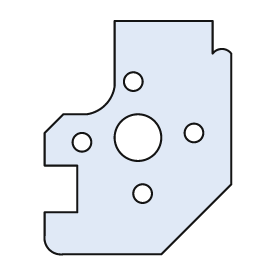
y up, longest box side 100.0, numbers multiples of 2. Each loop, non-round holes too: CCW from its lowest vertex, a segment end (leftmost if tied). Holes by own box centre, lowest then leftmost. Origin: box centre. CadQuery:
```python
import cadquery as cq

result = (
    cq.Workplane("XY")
    .moveTo(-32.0, -50.0)
    .lineTo(10.0, -50.0)
    .lineTo(40.0, -20.0)
    .lineTo(40.0, 36.0)
    .threePointArc((36.0, 38.0), (32.0, 36.0))
    .lineTo(32.0, 50.0)
    .lineTo(-10.0, 50.0)
    .lineTo(-10.0, 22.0)
    .threePointArc((-14.0, 14.0), (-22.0, 10.0))
    .lineTo(-32.0, 10.0)
    .lineTo(-40.0, 2.0)
    .lineTo(-40.0, -12.0)
    .lineTo(-26.0, -12.0)
    .lineTo(-26.0, -32.0)
    .lineTo(-40.0, -32.0)
    .lineTo(-40.0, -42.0)
    .threePointArc((-38.0, -48.0), (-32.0, -50.0))
    .close()
    .moveTo(2.0, -24.0)
    .circle(4.0)
    .moveTo(-24.0, -2.0)
    .circle(4.0)
    .moveTo(0.0, 0.0)
    .circle(10.0)
    .moveTo(24.0, 2.0)
    .circle(4.0)
    .moveTo(-2.0, 24.0)
    .circle(4.0)
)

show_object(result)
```